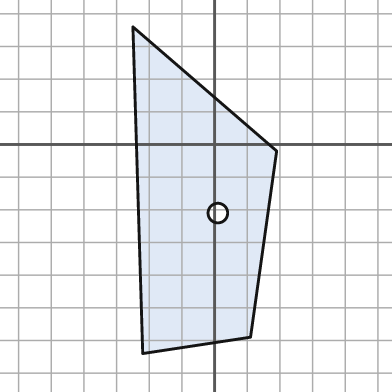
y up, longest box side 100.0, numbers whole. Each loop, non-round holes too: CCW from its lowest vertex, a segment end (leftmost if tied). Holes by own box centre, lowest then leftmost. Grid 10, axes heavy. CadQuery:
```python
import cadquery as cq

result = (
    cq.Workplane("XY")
    .moveTo(-22.0, -64.0)
    .lineTo(11.0, -59.0)
    .lineTo(19.0, -2.0)
    .lineTo(-25.0, 36.0)
    .close()
    .moveTo(1.0, -21.0)
    .circle(3.0)
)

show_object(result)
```